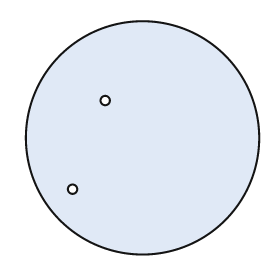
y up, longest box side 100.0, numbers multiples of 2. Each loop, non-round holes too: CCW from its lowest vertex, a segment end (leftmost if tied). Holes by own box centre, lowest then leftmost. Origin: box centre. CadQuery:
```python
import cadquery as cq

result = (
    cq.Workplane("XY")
    .moveTo(0.0, 0.0)
    .circle(50.0)
    .moveTo(-30.0, -22.0)
    .circle(2.0)
    .moveTo(-16.0, 16.0)
    .circle(2.0)
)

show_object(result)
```